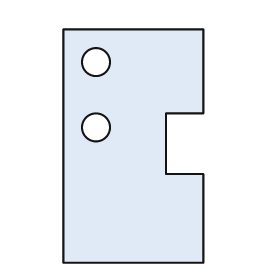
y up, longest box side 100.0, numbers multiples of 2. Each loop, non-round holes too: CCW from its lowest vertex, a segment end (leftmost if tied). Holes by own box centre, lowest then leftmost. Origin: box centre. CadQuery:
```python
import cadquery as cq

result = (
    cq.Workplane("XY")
    .moveTo(-30.0, -50.0)
    .lineTo(30.0, -50.0)
    .lineTo(30.0, -12.0)
    .lineTo(14.0, -12.0)
    .lineTo(14.0, 14.0)
    .lineTo(30.0, 14.0)
    .lineTo(30.0, 50.0)
    .lineTo(-30.0, 50.0)
    .close()
    .moveTo(-16.0, 8.0)
    .circle(6.0)
    .moveTo(-16.0, 36.0)
    .circle(6.0)
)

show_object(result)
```